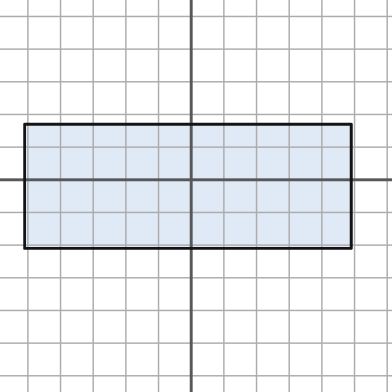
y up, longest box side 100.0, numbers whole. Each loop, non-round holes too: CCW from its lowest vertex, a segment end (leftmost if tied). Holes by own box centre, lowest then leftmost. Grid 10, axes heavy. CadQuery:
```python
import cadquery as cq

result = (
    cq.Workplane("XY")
    .moveTo(-51.0, -21.0)
    .lineTo(49.0, -21.0)
    .lineTo(49.0, 17.0)
    .lineTo(-51.0, 17.0)
    .close()
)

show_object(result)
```